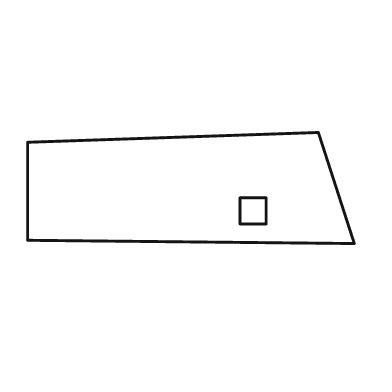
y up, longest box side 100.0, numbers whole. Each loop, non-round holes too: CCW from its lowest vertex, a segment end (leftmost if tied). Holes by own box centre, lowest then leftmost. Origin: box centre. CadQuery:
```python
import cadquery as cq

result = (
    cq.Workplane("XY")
    .moveTo(50.0, -17.0)
    .lineTo(39.0, 17.0)
    .lineTo(-50.0, 14.0)
    .lineTo(-50.0, -16.0)
    .close()
    .moveTo(15.0, -11.0)
    .lineTo(23.0, -11.0)
    .lineTo(23.0, -3.0)
    .lineTo(15.0, -3.0)
    .close()
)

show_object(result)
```